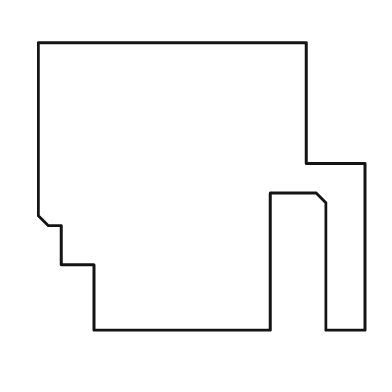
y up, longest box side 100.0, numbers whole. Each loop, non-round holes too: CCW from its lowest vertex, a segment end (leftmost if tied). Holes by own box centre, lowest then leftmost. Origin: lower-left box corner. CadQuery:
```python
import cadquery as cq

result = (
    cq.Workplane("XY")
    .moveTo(17.0, 0.0)
    .lineTo(71.0, 0.0)
    .lineTo(71.0, 42.0)
    .lineTo(85.0, 42.0)
    .lineTo(88.0, 39.0)
    .lineTo(88.0, 0.0)
    .lineTo(100.0, 0.0)
    .lineTo(100.0, 51.0)
    .lineTo(82.0, 51.0)
    .lineTo(82.0, 88.0)
    .lineTo(0.0, 88.0)
    .lineTo(0.0, 35.0)
    .lineTo(3.0, 32.0)
    .lineTo(7.0, 32.0)
    .lineTo(7.0, 20.0)
    .lineTo(17.0, 20.0)
    .close()
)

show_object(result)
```